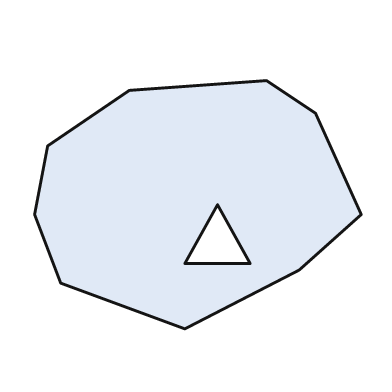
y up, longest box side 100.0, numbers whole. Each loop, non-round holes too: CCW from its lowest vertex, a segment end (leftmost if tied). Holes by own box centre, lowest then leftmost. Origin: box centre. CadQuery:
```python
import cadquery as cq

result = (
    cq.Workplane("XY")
    .moveTo(-4.0, -38.0)
    .lineTo(31.0, -20.0)
    .lineTo(50.0, -3.0)
    .lineTo(36.0, 28.0)
    .lineTo(21.0, 38.0)
    .lineTo(-21.0, 35.0)
    .lineTo(-46.0, 18.0)
    .lineTo(-50.0, -3.0)
    .lineTo(-42.0, -24.0)
    .close()
    .moveTo(-4.0, -18.0)
    .lineTo(16.0, -18.0)
    .lineTo(6.0, 0.0)
    .close()
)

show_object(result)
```